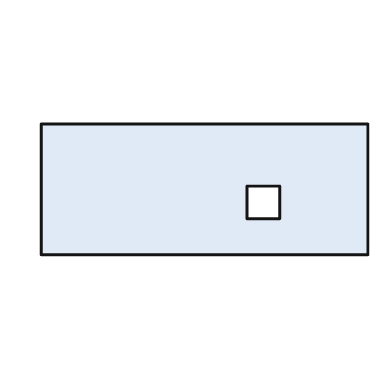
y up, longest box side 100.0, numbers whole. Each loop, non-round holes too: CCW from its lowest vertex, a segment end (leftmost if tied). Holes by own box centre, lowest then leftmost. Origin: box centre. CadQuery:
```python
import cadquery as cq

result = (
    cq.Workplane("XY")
    .moveTo(-50.0, -20.0)
    .lineTo(50.0, -20.0)
    .lineTo(50.0, 20.0)
    .lineTo(-50.0, 20.0)
    .close()
    .moveTo(13.0, -9.0)
    .lineTo(23.0, -9.0)
    .lineTo(23.0, 1.0)
    .lineTo(13.0, 1.0)
    .close()
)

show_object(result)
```